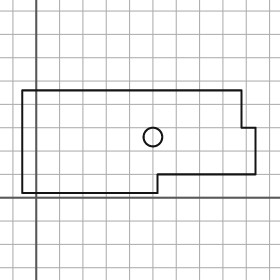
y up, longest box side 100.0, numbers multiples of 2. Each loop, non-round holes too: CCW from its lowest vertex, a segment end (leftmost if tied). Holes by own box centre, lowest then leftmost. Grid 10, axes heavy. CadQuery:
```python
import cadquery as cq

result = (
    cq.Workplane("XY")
    .moveTo(-6.0, 2.0)
    .lineTo(52.0, 2.0)
    .lineTo(52.0, 10.0)
    .lineTo(94.0, 10.0)
    .lineTo(94.0, 30.0)
    .lineTo(88.0, 30.0)
    .lineTo(88.0, 46.0)
    .lineTo(-6.0, 46.0)
    .close()
    .moveTo(50.0, 26.0)
    .circle(4.0)
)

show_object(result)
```